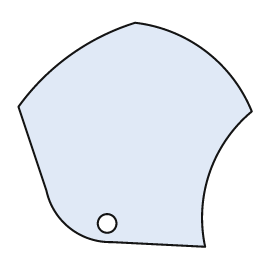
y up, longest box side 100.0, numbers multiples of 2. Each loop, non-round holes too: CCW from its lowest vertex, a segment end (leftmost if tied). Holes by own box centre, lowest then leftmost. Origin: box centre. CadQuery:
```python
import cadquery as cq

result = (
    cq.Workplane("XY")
    .moveTo(30.0, -48.0)
    .threePointArc((32.0, -16.0), (50.0, 10.0))
    .threePointArc((30.0, 36.0), (0.0, 48.0))
    .threePointArc((-28.0, 34.0), (-50.0, 12.0))
    .lineTo(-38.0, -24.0)
    .threePointArc((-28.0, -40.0), (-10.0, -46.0))
    .close()
    .moveTo(-12.0, -38.0)
    .circle(4.0)
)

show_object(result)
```